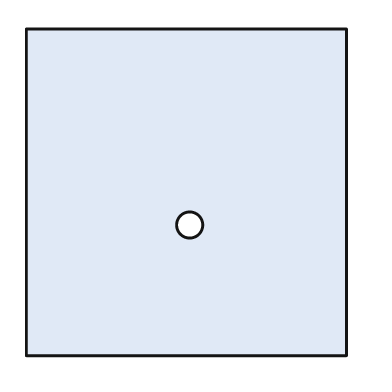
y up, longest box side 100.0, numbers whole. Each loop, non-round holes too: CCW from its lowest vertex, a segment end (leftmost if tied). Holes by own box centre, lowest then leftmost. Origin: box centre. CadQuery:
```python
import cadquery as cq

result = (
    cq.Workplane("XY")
    .moveTo(-49.0, -50.0)
    .lineTo(49.0, -50.0)
    .lineTo(49.0, 50.0)
    .lineTo(-49.0, 50.0)
    .close()
    .moveTo(1.0, -10.0)
    .circle(4.0)
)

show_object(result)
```